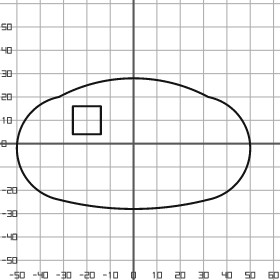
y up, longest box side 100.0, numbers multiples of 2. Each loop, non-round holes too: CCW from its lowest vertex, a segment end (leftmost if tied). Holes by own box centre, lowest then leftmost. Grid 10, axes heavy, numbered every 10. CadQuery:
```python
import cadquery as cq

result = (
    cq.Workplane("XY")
    .moveTo(-32.0, -24.0)
    .threePointArc((0.0, -28.0), (32.0, -24.0))
    .threePointArc((50.0, -2.0), (32.0, 20.0))
    .threePointArc((0.0, 28.0), (-32.0, 20.0))
    .threePointArc((-50.0, -2.0), (-32.0, -24.0))
    .close()
    .moveTo(-26.0, 4.0)
    .lineTo(-14.0, 4.0)
    .lineTo(-14.0, 16.0)
    .lineTo(-26.0, 16.0)
    .close()
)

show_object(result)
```